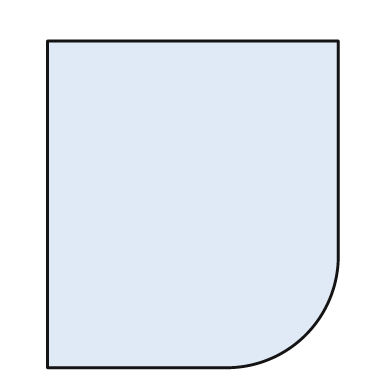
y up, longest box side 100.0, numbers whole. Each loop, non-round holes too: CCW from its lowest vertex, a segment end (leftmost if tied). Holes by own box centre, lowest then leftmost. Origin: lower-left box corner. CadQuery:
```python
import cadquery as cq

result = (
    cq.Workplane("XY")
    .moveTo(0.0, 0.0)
    .lineTo(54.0, 0.0)
    .threePointArc((79.0, 10.0), (89.0, 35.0))
    .lineTo(89.0, 100.0)
    .lineTo(0.0, 100.0)
    .close()
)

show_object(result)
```